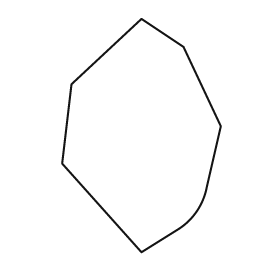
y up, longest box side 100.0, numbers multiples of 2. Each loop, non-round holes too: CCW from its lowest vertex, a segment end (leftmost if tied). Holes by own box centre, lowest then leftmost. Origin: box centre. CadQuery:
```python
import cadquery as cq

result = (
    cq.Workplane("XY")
    .moveTo(0.0, -50.0)
    .lineTo(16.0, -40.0)
    .threePointArc((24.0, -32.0), (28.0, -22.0))
    .lineTo(34.0, 4.0)
    .lineTo(18.0, 38.0)
    .lineTo(0.0, 50.0)
    .lineTo(-30.0, 22.0)
    .lineTo(-34.0, -12.0)
    .close()
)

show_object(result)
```